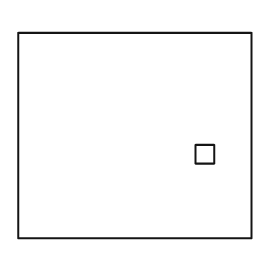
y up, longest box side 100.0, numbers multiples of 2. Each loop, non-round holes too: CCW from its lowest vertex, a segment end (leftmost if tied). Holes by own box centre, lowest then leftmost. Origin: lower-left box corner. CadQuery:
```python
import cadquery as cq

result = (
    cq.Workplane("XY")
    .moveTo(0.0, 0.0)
    .lineTo(100.0, 0.0)
    .lineTo(100.0, 88.0)
    .lineTo(0.0, 88.0)
    .close()
    .moveTo(76.0, 32.0)
    .lineTo(84.0, 32.0)
    .lineTo(84.0, 40.0)
    .lineTo(76.0, 40.0)
    .close()
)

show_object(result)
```